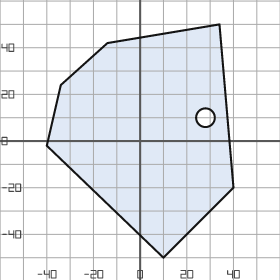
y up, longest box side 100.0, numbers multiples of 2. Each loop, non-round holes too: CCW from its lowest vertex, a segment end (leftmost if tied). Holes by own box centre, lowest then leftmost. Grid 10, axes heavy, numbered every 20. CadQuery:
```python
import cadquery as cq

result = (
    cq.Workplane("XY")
    .moveTo(10.0, -50.0)
    .lineTo(40.0, -20.0)
    .lineTo(34.0, 50.0)
    .lineTo(-14.0, 42.0)
    .lineTo(-34.0, 24.0)
    .lineTo(-40.0, -2.0)
    .close()
    .moveTo(28.0, 10.0)
    .circle(4.0)
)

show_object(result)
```